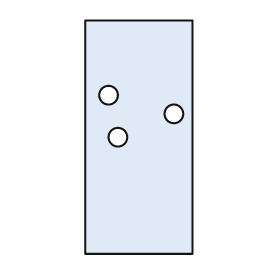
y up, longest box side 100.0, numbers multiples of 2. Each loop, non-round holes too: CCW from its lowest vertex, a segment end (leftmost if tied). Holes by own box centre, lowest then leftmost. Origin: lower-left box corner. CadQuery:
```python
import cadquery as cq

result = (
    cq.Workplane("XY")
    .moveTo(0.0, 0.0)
    .lineTo(46.0, 0.0)
    .lineTo(46.0, 100.0)
    .lineTo(0.0, 100.0)
    .close()
    .moveTo(14.0, 50.0)
    .circle(4.0)
    .moveTo(38.0, 60.0)
    .circle(4.0)
    .moveTo(10.0, 68.0)
    .circle(4.0)
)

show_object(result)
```